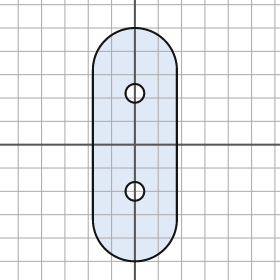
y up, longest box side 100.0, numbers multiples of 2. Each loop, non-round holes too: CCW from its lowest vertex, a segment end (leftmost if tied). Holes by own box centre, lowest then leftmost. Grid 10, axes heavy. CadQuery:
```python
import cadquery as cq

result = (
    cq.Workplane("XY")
    .moveTo(-18.0, -32.0)
    .threePointArc((0.0, -50.0), (18.0, -32.0))
    .lineTo(18.0, 32.0)
    .threePointArc((0.0, 50.0), (-18.0, 32.0))
    .close()
    .moveTo(0.0, -20.0)
    .circle(4.0)
    .moveTo(0.0, 22.0)
    .circle(4.0)
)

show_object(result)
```